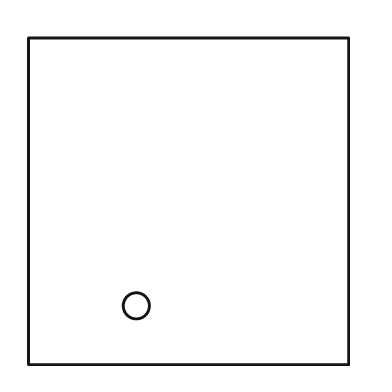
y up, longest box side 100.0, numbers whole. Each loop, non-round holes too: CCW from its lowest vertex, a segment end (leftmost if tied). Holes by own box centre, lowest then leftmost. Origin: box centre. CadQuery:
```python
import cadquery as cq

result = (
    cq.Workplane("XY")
    .moveTo(-49.0, -50.0)
    .lineTo(49.0, -50.0)
    .lineTo(49.0, 50.0)
    .lineTo(-49.0, 50.0)
    .close()
    .moveTo(-16.0, -32.0)
    .circle(4.0)
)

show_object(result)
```